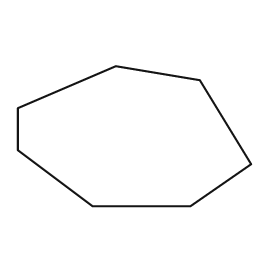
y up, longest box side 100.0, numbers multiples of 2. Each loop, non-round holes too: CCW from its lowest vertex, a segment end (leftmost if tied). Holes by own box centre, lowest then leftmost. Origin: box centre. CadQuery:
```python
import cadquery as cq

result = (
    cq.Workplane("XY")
    .moveTo(-18.0, -30.0)
    .lineTo(24.0, -30.0)
    .lineTo(50.0, -12.0)
    .lineTo(28.0, 24.0)
    .lineTo(-8.0, 30.0)
    .lineTo(-50.0, 12.0)
    .lineTo(-50.0, -6.0)
    .close()
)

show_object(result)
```